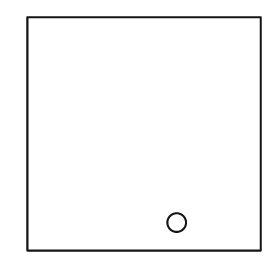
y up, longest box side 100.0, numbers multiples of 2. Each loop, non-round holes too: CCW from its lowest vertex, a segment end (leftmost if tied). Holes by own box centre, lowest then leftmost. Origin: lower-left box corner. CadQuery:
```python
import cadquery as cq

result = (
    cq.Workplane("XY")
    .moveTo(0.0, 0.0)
    .lineTo(100.0, 0.0)
    .lineTo(100.0, 100.0)
    .lineTo(0.0, 100.0)
    .close()
    .moveTo(64.0, 12.0)
    .circle(4.0)
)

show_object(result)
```